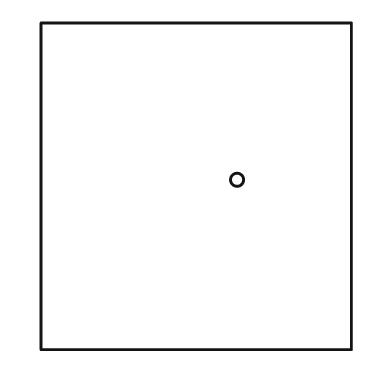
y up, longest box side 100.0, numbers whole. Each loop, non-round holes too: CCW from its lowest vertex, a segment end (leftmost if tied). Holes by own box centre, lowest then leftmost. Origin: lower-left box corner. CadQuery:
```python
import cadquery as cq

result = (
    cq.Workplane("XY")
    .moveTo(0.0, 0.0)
    .lineTo(95.0, 0.0)
    .lineTo(95.0, 100.0)
    .lineTo(0.0, 100.0)
    .close()
    .moveTo(60.0, 52.0)
    .circle(2.0)
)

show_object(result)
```